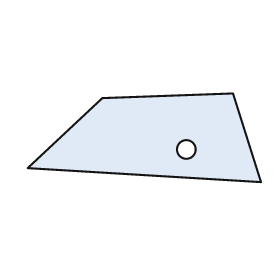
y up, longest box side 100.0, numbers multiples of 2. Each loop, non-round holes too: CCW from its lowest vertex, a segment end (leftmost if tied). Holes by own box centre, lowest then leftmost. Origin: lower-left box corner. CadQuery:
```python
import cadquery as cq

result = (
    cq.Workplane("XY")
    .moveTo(100.0, 0.0)
    .lineTo(88.0, 38.0)
    .lineTo(32.0, 36.0)
    .lineTo(0.0, 6.0)
    .close()
    .moveTo(68.0, 14.0)
    .circle(4.0)
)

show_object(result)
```